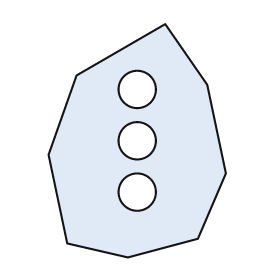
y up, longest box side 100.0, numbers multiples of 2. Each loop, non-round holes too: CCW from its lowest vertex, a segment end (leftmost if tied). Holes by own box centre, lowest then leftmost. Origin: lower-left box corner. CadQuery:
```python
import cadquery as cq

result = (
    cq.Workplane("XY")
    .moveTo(34.0, 0.0)
    .lineTo(64.0, 8.0)
    .lineTo(76.0, 36.0)
    .lineTo(68.0, 74.0)
    .lineTo(50.0, 100.0)
    .lineTo(12.0, 78.0)
    .lineTo(0.0, 44.0)
    .lineTo(8.0, 6.0)
    .close()
    .moveTo(38.0, 28.0)
    .circle(8.0)
    .moveTo(38.0, 50.0)
    .circle(8.0)
    .moveTo(38.0, 72.0)
    .circle(8.0)
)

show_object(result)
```